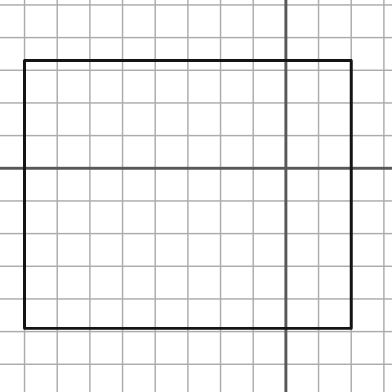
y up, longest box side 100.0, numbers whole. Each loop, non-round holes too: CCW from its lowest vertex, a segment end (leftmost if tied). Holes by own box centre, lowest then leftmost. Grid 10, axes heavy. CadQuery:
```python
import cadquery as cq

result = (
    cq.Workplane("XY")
    .moveTo(-80.0, -49.0)
    .lineTo(20.0, -49.0)
    .lineTo(20.0, 33.0)
    .lineTo(-80.0, 33.0)
    .close()
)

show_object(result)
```